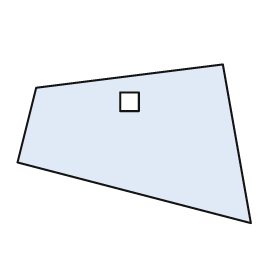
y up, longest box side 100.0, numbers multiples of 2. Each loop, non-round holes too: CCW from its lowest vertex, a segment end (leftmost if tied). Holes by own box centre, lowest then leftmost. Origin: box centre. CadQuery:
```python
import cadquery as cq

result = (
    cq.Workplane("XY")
    .moveTo(50.0, -34.0)
    .lineTo(38.0, 34.0)
    .lineTo(-42.0, 24.0)
    .lineTo(-50.0, -8.0)
    .close()
    .moveTo(-6.0, 14.0)
    .lineTo(2.0, 14.0)
    .lineTo(2.0, 22.0)
    .lineTo(-6.0, 22.0)
    .close()
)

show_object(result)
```